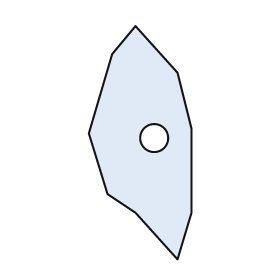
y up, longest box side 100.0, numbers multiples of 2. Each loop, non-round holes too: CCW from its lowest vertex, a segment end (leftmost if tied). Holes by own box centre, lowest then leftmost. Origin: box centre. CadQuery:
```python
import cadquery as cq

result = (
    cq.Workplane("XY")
    .moveTo(16.0, -50.0)
    .lineTo(22.0, -30.0)
    .lineTo(22.0, 6.0)
    .lineTo(16.0, 30.0)
    .lineTo(-2.0, 50.0)
    .lineTo(-12.0, 38.0)
    .lineTo(-22.0, 4.0)
    .lineTo(-14.0, -22.0)
    .lineTo(-2.0, -30.0)
    .close()
    .moveTo(6.0, 2.0)
    .circle(6.0)
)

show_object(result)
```